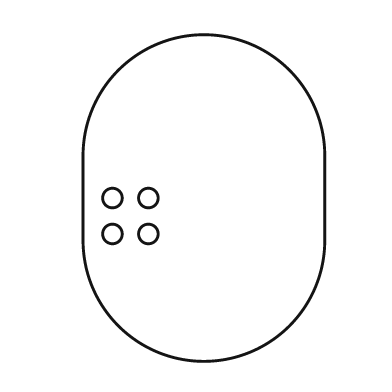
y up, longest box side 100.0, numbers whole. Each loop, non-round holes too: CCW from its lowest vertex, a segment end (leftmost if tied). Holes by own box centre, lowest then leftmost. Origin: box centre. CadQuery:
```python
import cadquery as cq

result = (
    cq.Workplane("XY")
    .moveTo(-37.0, -13.0)
    .threePointArc((0.0, -50.0), (37.0, -13.0))
    .lineTo(37.0, 13.0)
    .threePointArc((0.0, 50.0), (-37.0, 13.0))
    .close()
    .moveTo(-28.0, -11.0)
    .circle(3.0)
    .moveTo(-17.0, -11.0)
    .circle(3.0)
    .moveTo(-28.0, 0.0)
    .circle(3.0)
    .moveTo(-17.0, 0.0)
    .circle(3.0)
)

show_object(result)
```